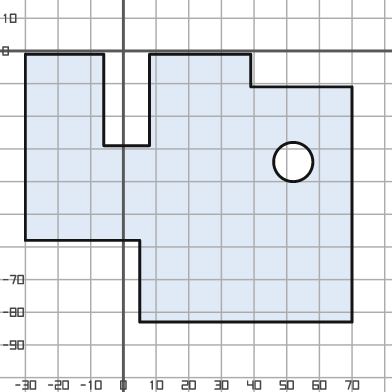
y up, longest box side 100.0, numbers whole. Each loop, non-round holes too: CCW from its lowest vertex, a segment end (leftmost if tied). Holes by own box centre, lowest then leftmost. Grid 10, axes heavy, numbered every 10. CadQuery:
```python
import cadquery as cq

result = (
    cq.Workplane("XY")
    .moveTo(5.0, -83.0)
    .lineTo(70.0, -83.0)
    .lineTo(70.0, -11.0)
    .lineTo(39.0, -11.0)
    .lineTo(39.0, -1.0)
    .lineTo(8.0, -1.0)
    .lineTo(8.0, -29.0)
    .lineTo(-6.0, -29.0)
    .lineTo(-6.0, -1.0)
    .lineTo(-30.0, -1.0)
    .lineTo(-30.0, -58.0)
    .lineTo(5.0, -58.0)
    .close()
    .moveTo(52.0, -34.0)
    .circle(6.0)
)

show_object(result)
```